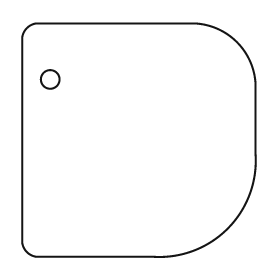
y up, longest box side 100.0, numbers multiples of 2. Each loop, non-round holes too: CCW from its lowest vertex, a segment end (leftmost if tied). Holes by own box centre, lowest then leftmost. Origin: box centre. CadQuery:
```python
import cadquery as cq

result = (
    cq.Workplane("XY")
    .moveTo(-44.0, -50.0)
    .lineTo(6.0, -50.0)
    .threePointArc((38.0, -38.0), (50.0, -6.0))
    .lineTo(50.0, 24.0)
    .threePointArc((42.0, 42.0), (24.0, 50.0))
    .lineTo(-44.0, 50.0)
    .threePointArc((-48.0, 48.0), (-50.0, 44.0))
    .lineTo(-50.0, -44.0)
    .threePointArc((-48.0, -48.0), (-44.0, -50.0))
    .close()
    .moveTo(-38.0, 26.0)
    .circle(4.0)
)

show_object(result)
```